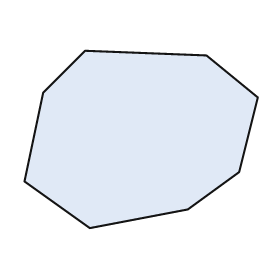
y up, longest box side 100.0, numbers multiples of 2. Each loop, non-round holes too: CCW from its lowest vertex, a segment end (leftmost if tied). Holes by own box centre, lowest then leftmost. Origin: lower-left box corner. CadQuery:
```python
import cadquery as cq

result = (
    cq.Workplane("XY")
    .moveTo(28.0, 0.0)
    .lineTo(70.0, 8.0)
    .lineTo(92.0, 24.0)
    .lineTo(100.0, 56.0)
    .lineTo(78.0, 74.0)
    .lineTo(26.0, 76.0)
    .lineTo(8.0, 58.0)
    .lineTo(0.0, 20.0)
    .close()
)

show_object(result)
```